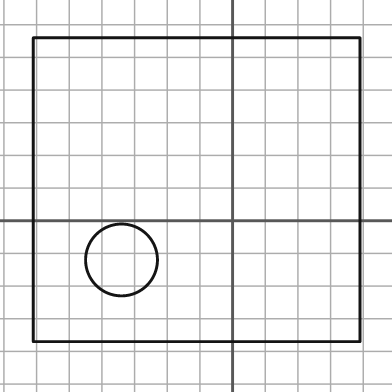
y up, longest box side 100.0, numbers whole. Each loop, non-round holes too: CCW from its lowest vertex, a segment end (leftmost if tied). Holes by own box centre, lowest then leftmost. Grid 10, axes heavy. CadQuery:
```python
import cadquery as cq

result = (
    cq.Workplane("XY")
    .moveTo(-61.0, -37.0)
    .lineTo(39.0, -37.0)
    .lineTo(39.0, 56.0)
    .lineTo(-61.0, 56.0)
    .close()
    .moveTo(-34.0, -12.0)
    .circle(11.0)
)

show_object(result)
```